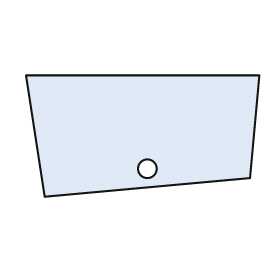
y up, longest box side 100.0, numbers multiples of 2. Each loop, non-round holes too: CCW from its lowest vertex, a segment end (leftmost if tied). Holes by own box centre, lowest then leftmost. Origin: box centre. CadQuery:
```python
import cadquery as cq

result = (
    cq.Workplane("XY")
    .moveTo(-42.0, -26.0)
    .lineTo(46.0, -18.0)
    .lineTo(50.0, 26.0)
    .lineTo(-50.0, 26.0)
    .close()
    .moveTo(2.0, -14.0)
    .circle(4.0)
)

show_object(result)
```